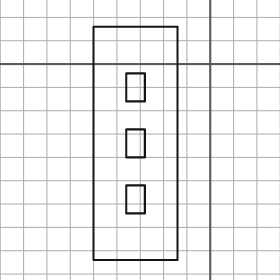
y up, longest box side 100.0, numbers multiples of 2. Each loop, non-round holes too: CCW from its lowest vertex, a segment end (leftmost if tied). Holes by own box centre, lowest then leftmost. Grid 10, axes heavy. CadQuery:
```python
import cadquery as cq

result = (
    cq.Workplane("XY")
    .moveTo(-50.0, -84.0)
    .lineTo(-14.0, -84.0)
    .lineTo(-14.0, 16.0)
    .lineTo(-50.0, 16.0)
    .close()
    .moveTo(-36.0, -64.0)
    .lineTo(-28.0, -64.0)
    .lineTo(-28.0, -52.0)
    .lineTo(-36.0, -52.0)
    .close()
    .moveTo(-36.0, -40.0)
    .lineTo(-28.0, -40.0)
    .lineTo(-28.0, -28.0)
    .lineTo(-36.0, -28.0)
    .close()
    .moveTo(-36.0, -16.0)
    .lineTo(-28.0, -16.0)
    .lineTo(-28.0, -4.0)
    .lineTo(-36.0, -4.0)
    .close()
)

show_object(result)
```